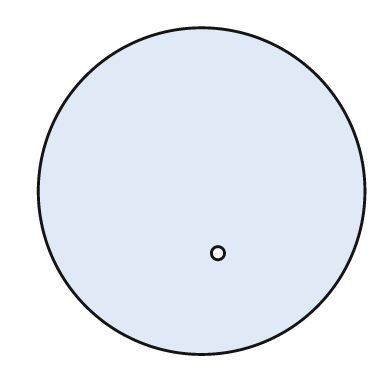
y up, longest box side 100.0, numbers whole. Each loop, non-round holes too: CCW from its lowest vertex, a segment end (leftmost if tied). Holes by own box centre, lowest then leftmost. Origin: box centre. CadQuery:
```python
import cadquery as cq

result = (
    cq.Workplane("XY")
    .moveTo(0.0, 0.0)
    .circle(50.0)
    .moveTo(5.0, -19.0)
    .circle(2.0)
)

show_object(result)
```